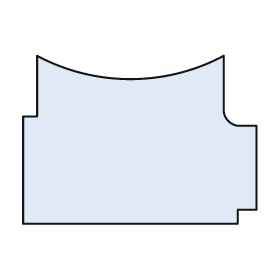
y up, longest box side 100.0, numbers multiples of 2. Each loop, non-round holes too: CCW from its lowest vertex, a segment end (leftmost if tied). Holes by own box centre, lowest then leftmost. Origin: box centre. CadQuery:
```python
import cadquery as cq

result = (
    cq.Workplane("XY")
    .moveTo(-50.0, -36.0)
    .lineTo(42.0, -36.0)
    .lineTo(42.0, -30.0)
    .lineTo(50.0, -30.0)
    .lineTo(50.0, 6.0)
    .lineTo(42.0, 6.0)
    .threePointArc((38.0, 8.0), (36.0, 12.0))
    .lineTo(36.0, 36.0)
    .threePointArc((-4.0, 26.0), (-44.0, 36.0))
    .lineTo(-44.0, 10.0)
    .lineTo(-50.0, 10.0)
    .close()
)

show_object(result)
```